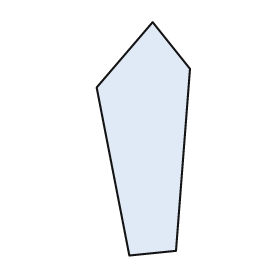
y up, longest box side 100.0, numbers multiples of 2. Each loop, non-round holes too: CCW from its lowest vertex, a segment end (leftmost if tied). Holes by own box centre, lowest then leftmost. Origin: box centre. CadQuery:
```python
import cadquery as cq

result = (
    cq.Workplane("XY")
    .moveTo(-6.0, -50.0)
    .lineTo(14.0, -48.0)
    .lineTo(20.0, 30.0)
    .lineTo(4.0, 50.0)
    .lineTo(-20.0, 22.0)
    .close()
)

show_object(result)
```